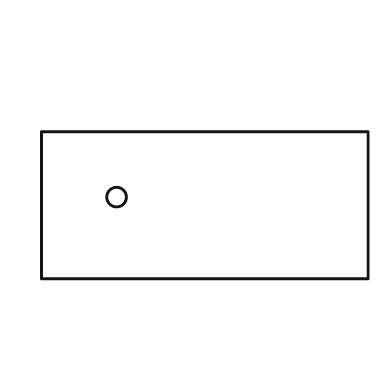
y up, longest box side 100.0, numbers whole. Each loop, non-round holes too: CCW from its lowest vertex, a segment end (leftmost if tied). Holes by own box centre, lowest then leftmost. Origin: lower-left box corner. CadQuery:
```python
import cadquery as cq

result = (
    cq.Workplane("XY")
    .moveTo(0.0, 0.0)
    .lineTo(100.0, 0.0)
    .lineTo(100.0, 45.0)
    .lineTo(0.0, 45.0)
    .close()
    .moveTo(23.0, 25.0)
    .circle(3.0)
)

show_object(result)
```